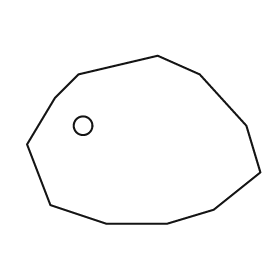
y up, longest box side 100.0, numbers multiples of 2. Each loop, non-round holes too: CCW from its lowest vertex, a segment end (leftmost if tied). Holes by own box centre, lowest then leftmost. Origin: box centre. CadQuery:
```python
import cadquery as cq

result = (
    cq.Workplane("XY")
    .moveTo(-16.0, -36.0)
    .lineTo(10.0, -36.0)
    .lineTo(30.0, -30.0)
    .lineTo(50.0, -14.0)
    .lineTo(44.0, 6.0)
    .lineTo(24.0, 28.0)
    .lineTo(6.0, 36.0)
    .lineTo(-28.0, 28.0)
    .lineTo(-38.0, 18.0)
    .lineTo(-50.0, -2.0)
    .lineTo(-40.0, -28.0)
    .close()
    .moveTo(-26.0, 6.0)
    .circle(4.0)
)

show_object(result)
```